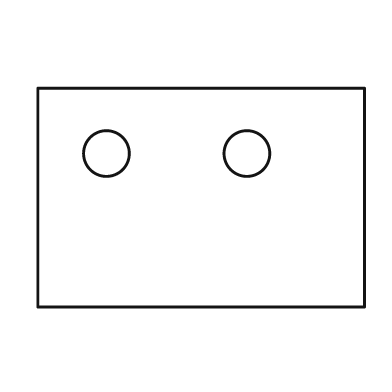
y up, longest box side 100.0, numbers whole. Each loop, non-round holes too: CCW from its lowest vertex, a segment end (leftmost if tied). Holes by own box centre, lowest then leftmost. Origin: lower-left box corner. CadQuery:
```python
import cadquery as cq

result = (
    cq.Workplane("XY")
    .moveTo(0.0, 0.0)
    .lineTo(100.0, 0.0)
    .lineTo(100.0, 67.0)
    .lineTo(0.0, 67.0)
    .close()
    .moveTo(21.0, 47.0)
    .circle(7.0)
    .moveTo(64.0, 47.0)
    .circle(7.0)
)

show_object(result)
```